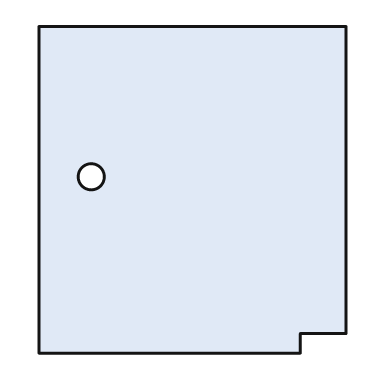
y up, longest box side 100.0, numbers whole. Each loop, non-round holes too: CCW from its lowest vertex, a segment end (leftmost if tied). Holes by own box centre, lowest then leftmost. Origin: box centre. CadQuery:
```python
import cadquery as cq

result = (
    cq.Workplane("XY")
    .moveTo(-47.0, -50.0)
    .lineTo(33.0, -50.0)
    .lineTo(33.0, -44.0)
    .lineTo(47.0, -44.0)
    .lineTo(47.0, 50.0)
    .lineTo(-47.0, 50.0)
    .close()
    .moveTo(-31.0, 4.0)
    .circle(4.0)
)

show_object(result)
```